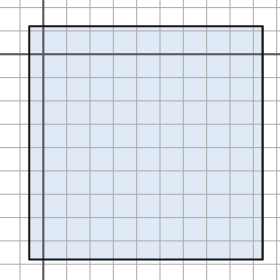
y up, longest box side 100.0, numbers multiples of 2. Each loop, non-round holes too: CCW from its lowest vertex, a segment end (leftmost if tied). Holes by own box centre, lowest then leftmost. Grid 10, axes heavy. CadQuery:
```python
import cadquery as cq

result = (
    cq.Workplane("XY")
    .moveTo(-6.0, -88.0)
    .lineTo(94.0, -88.0)
    .lineTo(94.0, 12.0)
    .lineTo(-6.0, 12.0)
    .close()
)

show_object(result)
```